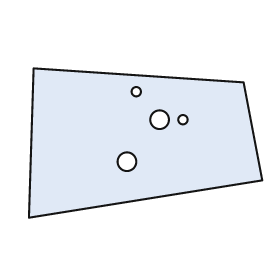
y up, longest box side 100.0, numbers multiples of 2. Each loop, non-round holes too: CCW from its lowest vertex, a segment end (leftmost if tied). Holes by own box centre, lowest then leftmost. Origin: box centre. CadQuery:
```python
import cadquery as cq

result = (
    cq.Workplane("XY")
    .moveTo(-50.0, -32.0)
    .lineTo(50.0, -16.0)
    .lineTo(42.0, 26.0)
    .lineTo(-48.0, 32.0)
    .close()
    .moveTo(-8.0, -8.0)
    .circle(4.0)
    .moveTo(6.0, 10.0)
    .circle(4.0)
    .moveTo(16.0, 10.0)
    .circle(2.0)
    .moveTo(-4.0, 22.0)
    .circle(2.0)
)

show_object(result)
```